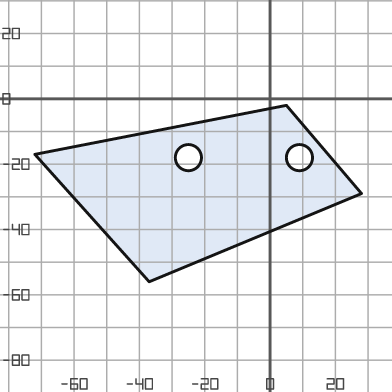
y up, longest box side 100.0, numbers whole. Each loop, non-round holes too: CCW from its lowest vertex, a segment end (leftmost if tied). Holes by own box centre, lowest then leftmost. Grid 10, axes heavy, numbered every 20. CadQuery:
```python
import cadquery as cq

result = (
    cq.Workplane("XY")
    .moveTo(-37.0, -56.0)
    .lineTo(28.0, -29.0)
    .lineTo(5.0, -2.0)
    .lineTo(-72.0, -17.0)
    .close()
    .moveTo(-25.0, -18.0)
    .circle(4.0)
    .moveTo(9.0, -18.0)
    .circle(4.0)
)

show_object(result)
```